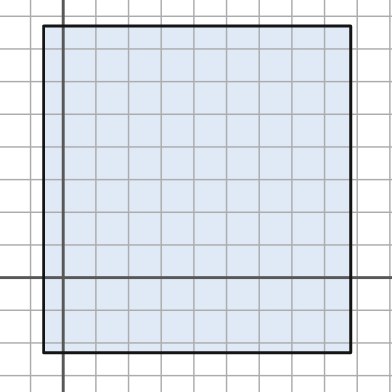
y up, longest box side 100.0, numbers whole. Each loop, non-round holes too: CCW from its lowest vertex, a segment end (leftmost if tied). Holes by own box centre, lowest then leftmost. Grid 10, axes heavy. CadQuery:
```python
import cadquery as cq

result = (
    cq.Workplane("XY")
    .moveTo(-6.0, -23.0)
    .lineTo(88.0, -23.0)
    .lineTo(88.0, 77.0)
    .lineTo(-6.0, 77.0)
    .close()
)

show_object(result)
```